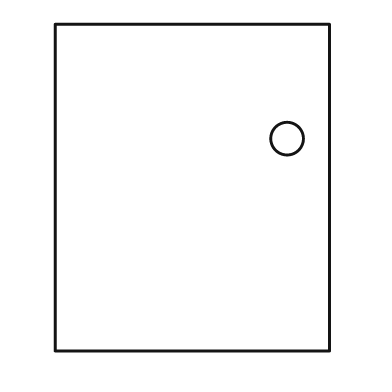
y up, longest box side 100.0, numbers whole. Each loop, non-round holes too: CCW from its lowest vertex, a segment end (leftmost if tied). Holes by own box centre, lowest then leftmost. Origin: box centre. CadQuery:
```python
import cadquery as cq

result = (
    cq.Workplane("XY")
    .moveTo(-42.0, -50.0)
    .lineTo(42.0, -50.0)
    .lineTo(42.0, 50.0)
    .lineTo(-42.0, 50.0)
    .close()
    .moveTo(29.0, 15.0)
    .circle(5.0)
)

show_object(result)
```